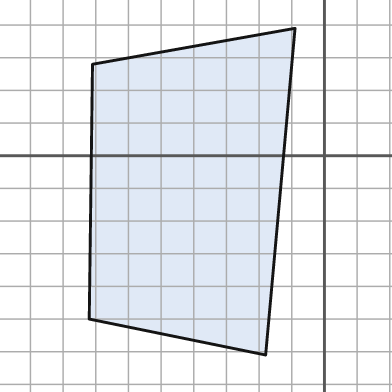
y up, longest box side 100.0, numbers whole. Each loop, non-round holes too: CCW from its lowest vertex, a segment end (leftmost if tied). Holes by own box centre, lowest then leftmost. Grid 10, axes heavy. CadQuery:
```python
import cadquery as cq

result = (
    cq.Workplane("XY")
    .moveTo(-18.0, -61.0)
    .lineTo(-9.0, 39.0)
    .lineTo(-71.0, 28.0)
    .lineTo(-72.0, -50.0)
    .close()
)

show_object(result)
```